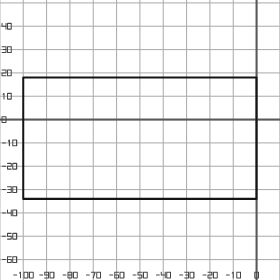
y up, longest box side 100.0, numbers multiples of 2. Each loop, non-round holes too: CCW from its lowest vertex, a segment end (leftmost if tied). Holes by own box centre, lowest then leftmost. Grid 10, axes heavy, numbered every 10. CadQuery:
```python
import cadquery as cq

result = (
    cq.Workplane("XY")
    .moveTo(-100.0, -34.0)
    .lineTo(0.0, -34.0)
    .lineTo(0.0, 18.0)
    .lineTo(-100.0, 18.0)
    .close()
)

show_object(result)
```